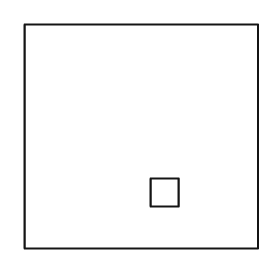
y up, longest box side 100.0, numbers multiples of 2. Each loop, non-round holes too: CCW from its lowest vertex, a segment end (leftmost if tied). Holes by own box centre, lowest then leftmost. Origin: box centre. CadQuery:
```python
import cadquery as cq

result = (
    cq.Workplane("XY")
    .moveTo(-50.0, -48.0)
    .lineTo(50.0, -48.0)
    .lineTo(50.0, 48.0)
    .lineTo(-50.0, 48.0)
    .close()
    .moveTo(4.0, -30.0)
    .lineTo(16.0, -30.0)
    .lineTo(16.0, -18.0)
    .lineTo(4.0, -18.0)
    .close()
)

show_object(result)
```